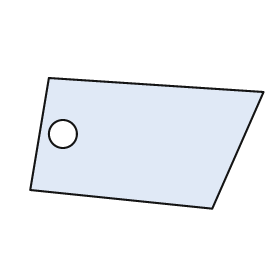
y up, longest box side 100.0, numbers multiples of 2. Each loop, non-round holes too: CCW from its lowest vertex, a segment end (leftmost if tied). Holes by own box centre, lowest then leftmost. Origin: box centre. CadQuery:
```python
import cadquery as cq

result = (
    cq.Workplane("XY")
    .moveTo(28.0, -28.0)
    .lineTo(50.0, 22.0)
    .lineTo(-42.0, 28.0)
    .lineTo(-50.0, -20.0)
    .close()
    .moveTo(-36.0, 4.0)
    .circle(6.0)
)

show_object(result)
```